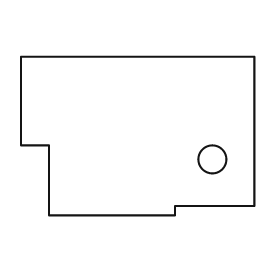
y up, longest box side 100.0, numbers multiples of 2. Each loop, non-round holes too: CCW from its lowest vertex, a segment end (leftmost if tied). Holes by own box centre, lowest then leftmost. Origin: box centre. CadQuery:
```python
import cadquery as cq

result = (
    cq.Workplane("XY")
    .moveTo(-38.0, -34.0)
    .lineTo(16.0, -34.0)
    .lineTo(16.0, -30.0)
    .lineTo(50.0, -30.0)
    .lineTo(50.0, 34.0)
    .lineTo(-50.0, 34.0)
    .lineTo(-50.0, -4.0)
    .lineTo(-38.0, -4.0)
    .close()
    .moveTo(32.0, -10.0)
    .circle(6.0)
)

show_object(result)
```